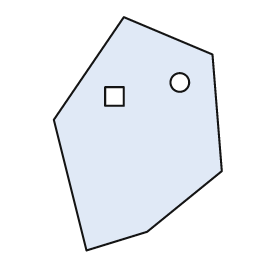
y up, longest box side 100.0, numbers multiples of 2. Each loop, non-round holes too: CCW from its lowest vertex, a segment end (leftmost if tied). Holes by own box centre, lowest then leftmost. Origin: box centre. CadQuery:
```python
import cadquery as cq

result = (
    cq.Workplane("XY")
    .moveTo(-22.0, -50.0)
    .lineTo(4.0, -42.0)
    .lineTo(36.0, -16.0)
    .lineTo(32.0, 34.0)
    .lineTo(-6.0, 50.0)
    .lineTo(-36.0, 6.0)
    .close()
    .moveTo(-14.0, 12.0)
    .lineTo(-6.0, 12.0)
    .lineTo(-6.0, 20.0)
    .lineTo(-14.0, 20.0)
    .close()
    .moveTo(18.0, 22.0)
    .circle(4.0)
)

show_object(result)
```